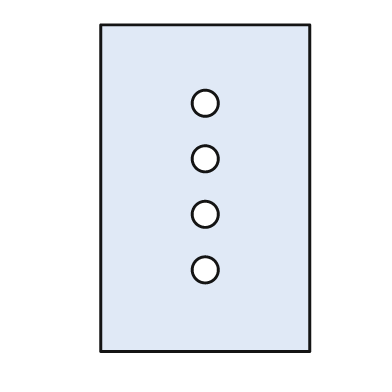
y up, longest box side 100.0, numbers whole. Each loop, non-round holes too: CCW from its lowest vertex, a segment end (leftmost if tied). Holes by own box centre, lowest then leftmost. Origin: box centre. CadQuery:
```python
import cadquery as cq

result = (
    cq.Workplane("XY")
    .moveTo(-32.0, -50.0)
    .lineTo(32.0, -50.0)
    .lineTo(32.0, 50.0)
    .lineTo(-32.0, 50.0)
    .close()
    .moveTo(0.0, -25.0)
    .circle(4.0)
    .moveTo(0.0, -8.0)
    .circle(4.0)
    .moveTo(0.0, 9.0)
    .circle(4.0)
    .moveTo(0.0, 26.0)
    .circle(4.0)
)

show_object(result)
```